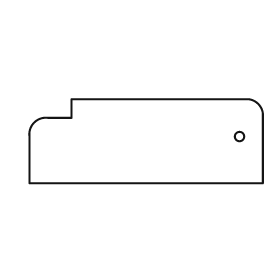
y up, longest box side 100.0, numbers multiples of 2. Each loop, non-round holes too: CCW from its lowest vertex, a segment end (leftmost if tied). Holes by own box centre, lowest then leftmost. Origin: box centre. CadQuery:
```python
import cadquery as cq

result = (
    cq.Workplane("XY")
    .moveTo(-50.0, -18.0)
    .lineTo(50.0, -18.0)
    .lineTo(50.0, 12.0)
    .threePointArc((48.0, 16.0), (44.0, 18.0))
    .lineTo(-32.0, 18.0)
    .lineTo(-32.0, 10.0)
    .lineTo(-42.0, 10.0)
    .threePointArc((-48.0, 8.0), (-50.0, 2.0))
    .close()
    .moveTo(40.0, 2.0)
    .circle(2.0)
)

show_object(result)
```